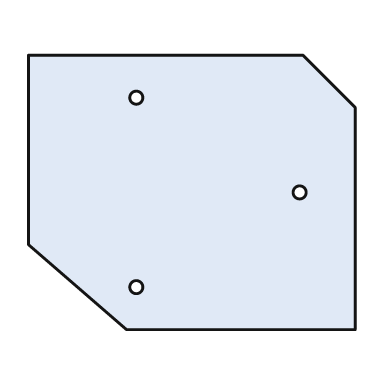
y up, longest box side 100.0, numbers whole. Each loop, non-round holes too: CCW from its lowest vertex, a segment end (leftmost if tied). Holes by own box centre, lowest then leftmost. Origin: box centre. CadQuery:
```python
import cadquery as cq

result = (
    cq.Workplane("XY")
    .moveTo(-20.0, -42.0)
    .lineTo(50.0, -42.0)
    .lineTo(50.0, 26.0)
    .lineTo(34.0, 42.0)
    .lineTo(-50.0, 42.0)
    .lineTo(-50.0, -16.0)
    .close()
    .moveTo(-17.0, -29.0)
    .circle(2.0)
    .moveTo(33.0, 0.0)
    .circle(2.0)
    .moveTo(-17.0, 29.0)
    .circle(2.0)
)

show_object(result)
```